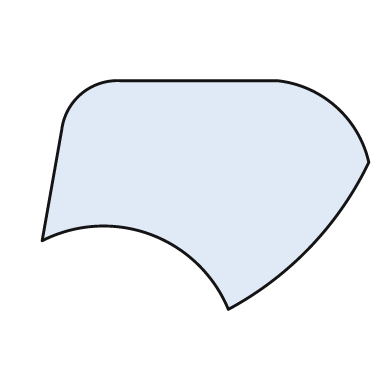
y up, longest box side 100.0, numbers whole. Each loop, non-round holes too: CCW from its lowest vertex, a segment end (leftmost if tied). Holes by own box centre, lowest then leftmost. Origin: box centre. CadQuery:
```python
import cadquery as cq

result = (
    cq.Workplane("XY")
    .moveTo(7.0, -35.0)
    .threePointArc((32.0, -16.0), (50.0, 10.0))
    .threePointArc((40.0, 27.0), (22.0, 35.0))
    .lineTo(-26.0, 35.0)
    .threePointArc((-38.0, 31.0), (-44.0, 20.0))
    .lineTo(-50.0, -14.0)
    .threePointArc((-17.0, -12.0), (7.0, -35.0))
    .close()
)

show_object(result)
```